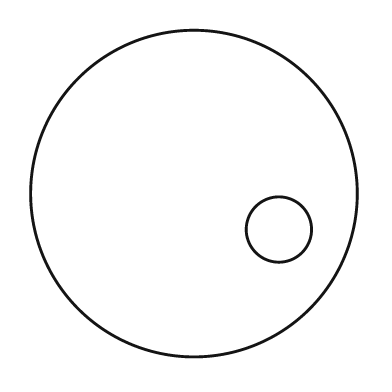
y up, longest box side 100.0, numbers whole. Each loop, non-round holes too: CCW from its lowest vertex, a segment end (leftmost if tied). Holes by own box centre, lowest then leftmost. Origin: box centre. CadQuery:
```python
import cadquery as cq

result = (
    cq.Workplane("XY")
    .moveTo(0.0, 0.0)
    .circle(50.0)
    .moveTo(26.0, -11.0)
    .circle(10.0)
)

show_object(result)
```